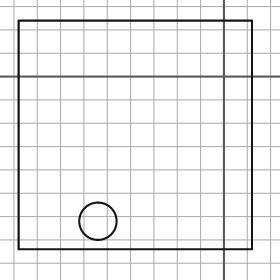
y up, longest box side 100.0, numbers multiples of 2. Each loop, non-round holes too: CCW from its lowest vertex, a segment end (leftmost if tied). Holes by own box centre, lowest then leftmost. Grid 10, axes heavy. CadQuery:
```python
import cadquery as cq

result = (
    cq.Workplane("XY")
    .moveTo(-88.0, -74.0)
    .lineTo(12.0, -74.0)
    .lineTo(12.0, 24.0)
    .lineTo(-88.0, 24.0)
    .close()
    .moveTo(-54.0, -62.0)
    .circle(8.0)
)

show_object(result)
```